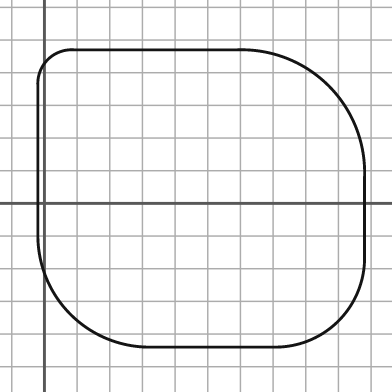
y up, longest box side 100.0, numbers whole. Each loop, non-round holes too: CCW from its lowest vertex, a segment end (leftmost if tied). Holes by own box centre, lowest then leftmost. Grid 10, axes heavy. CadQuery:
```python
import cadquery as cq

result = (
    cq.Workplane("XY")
    .moveTo(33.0, -44.0)
    .lineTo(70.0, -44.0)
    .threePointArc((90.0, -36.0), (98.0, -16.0))
    .lineTo(98.0, 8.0)
    .threePointArc((87.0, 36.0), (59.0, 47.0))
    .lineTo(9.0, 47.0)
    .threePointArc((1.0, 44.0), (-2.0, 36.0))
    .lineTo(-2.0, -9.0)
    .threePointArc((8.0, -34.0), (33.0, -44.0))
    .close()
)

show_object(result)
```